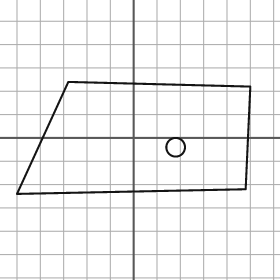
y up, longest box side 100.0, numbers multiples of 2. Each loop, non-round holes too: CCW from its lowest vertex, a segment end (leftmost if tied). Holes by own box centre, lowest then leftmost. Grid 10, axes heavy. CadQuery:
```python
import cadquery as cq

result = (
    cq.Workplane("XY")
    .moveTo(-50.0, -24.0)
    .lineTo(48.0, -22.0)
    .lineTo(50.0, 22.0)
    .lineTo(-28.0, 24.0)
    .close()
    .moveTo(18.0, -4.0)
    .circle(4.0)
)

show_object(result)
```